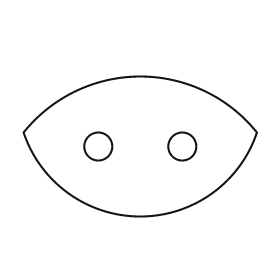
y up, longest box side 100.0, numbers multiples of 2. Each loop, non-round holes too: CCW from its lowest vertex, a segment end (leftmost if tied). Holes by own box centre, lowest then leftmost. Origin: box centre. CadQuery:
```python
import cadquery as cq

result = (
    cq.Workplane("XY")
    .moveTo(-50.0, 6.0)
    .threePointArc((0.0, -30.0), (50.0, 6.0))
    .threePointArc((0.0, 30.0), (-50.0, 6.0))
    .close()
    .moveTo(-18.0, 0.0)
    .circle(6.0)
    .moveTo(18.0, 0.0)
    .circle(6.0)
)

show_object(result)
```